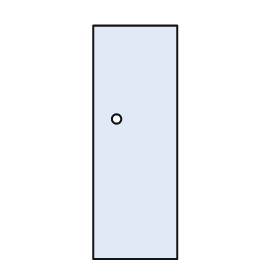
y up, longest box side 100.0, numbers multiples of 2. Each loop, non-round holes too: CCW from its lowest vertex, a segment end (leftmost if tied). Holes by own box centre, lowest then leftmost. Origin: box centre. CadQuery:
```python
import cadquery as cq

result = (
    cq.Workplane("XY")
    .moveTo(-18.0, -50.0)
    .lineTo(18.0, -50.0)
    .lineTo(18.0, 50.0)
    .lineTo(-18.0, 50.0)
    .close()
    .moveTo(-8.0, 10.0)
    .circle(2.0)
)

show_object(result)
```